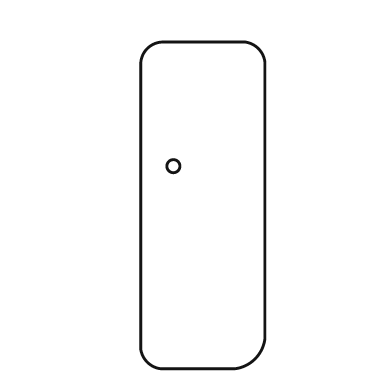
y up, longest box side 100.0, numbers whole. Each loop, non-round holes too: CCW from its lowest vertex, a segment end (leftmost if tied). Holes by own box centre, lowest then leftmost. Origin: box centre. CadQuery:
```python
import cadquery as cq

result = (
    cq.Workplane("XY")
    .moveTo(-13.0, -50.0)
    .lineTo(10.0, -50.0)
    .threePointArc((16.0, -47.0), (19.0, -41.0))
    .lineTo(19.0, 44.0)
    .threePointArc((17.0, 48.0), (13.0, 50.0))
    .lineTo(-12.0, 50.0)
    .threePointArc((-17.0, 48.0), (-19.0, 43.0))
    .lineTo(-19.0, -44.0)
    .threePointArc((-17.0, -48.0), (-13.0, -50.0))
    .close()
    .moveTo(-9.0, 12.0)
    .circle(2.0)
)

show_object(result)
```